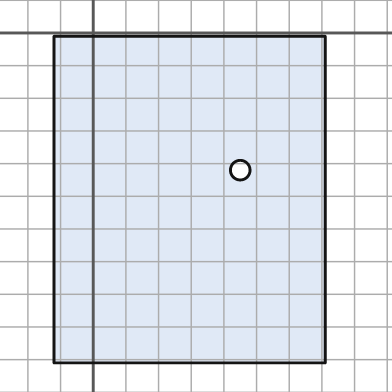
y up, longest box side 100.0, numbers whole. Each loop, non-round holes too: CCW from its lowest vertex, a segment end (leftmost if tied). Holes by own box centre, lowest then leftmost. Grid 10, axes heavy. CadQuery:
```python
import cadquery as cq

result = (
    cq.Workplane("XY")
    .moveTo(-12.0, -101.0)
    .lineTo(71.0, -101.0)
    .lineTo(71.0, -1.0)
    .lineTo(-12.0, -1.0)
    .close()
    .moveTo(45.0, -42.0)
    .circle(3.0)
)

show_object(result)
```